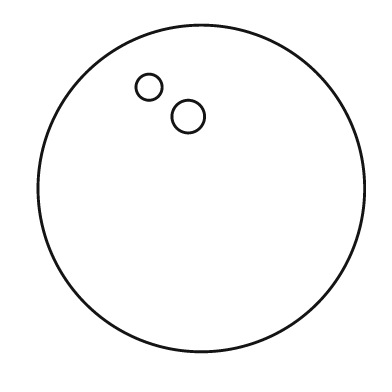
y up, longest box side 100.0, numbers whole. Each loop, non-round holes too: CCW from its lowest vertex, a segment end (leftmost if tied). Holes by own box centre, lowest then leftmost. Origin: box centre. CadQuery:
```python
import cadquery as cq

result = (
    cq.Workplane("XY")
    .moveTo(0.0, 0.0)
    .circle(50.0)
    .moveTo(-4.0, 22.0)
    .circle(5.0)
    .moveTo(-16.0, 31.0)
    .circle(4.0)
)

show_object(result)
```